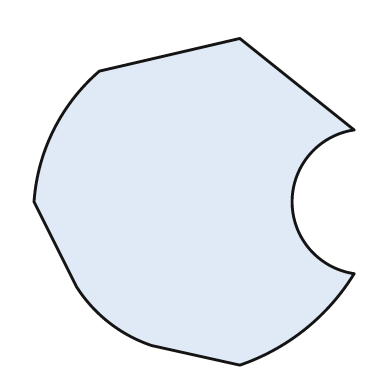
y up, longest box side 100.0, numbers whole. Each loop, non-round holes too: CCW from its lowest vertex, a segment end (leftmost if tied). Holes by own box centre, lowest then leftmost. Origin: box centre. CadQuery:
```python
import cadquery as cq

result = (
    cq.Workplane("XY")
    .moveTo(14.0, -50.0)
    .threePointArc((34.0, -39.0), (49.0, -22.0))
    .threePointArc((30.0, 0.0), (49.0, 22.0))
    .lineTo(14.0, 50.0)
    .lineTo(-29.0, 40.0)
    .threePointArc((-43.0, 22.0), (-49.0, 0.0))
    .lineTo(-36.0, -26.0)
    .threePointArc((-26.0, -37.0), (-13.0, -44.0))
    .close()
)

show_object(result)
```